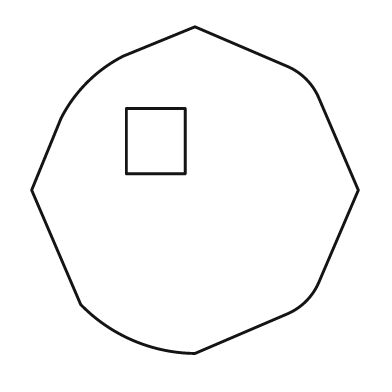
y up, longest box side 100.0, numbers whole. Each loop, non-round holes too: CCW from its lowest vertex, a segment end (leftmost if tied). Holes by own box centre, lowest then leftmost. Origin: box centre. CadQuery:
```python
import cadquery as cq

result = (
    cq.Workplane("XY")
    .moveTo(0.0, -50.0)
    .lineTo(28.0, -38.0)
    .threePointArc((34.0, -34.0), (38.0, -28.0))
    .lineTo(50.0, 0.0)
    .lineTo(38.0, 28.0)
    .threePointArc((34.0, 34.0), (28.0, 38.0))
    .lineTo(0.0, 50.0)
    .lineTo(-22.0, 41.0)
    .threePointArc((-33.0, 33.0), (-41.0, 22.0))
    .lineTo(-50.0, 0.0)
    .lineTo(-35.0, -35.0)
    .threePointArc((-19.0, -46.0), (0.0, -50.0))
    .close()
    .moveTo(-21.0, 5.0)
    .lineTo(-3.0, 5.0)
    .lineTo(-3.0, 25.0)
    .lineTo(-21.0, 25.0)
    .close()
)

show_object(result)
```